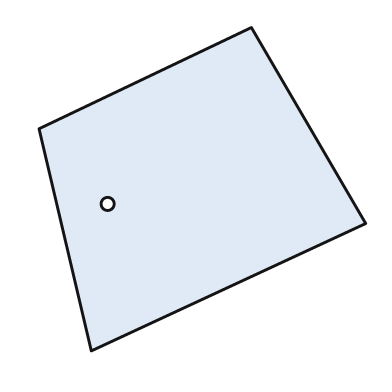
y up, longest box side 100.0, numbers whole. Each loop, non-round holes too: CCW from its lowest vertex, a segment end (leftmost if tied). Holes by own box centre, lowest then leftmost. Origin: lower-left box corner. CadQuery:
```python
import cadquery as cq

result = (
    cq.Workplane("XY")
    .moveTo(16.0, 0.0)
    .lineTo(100.0, 39.0)
    .lineTo(65.0, 99.0)
    .lineTo(0.0, 68.0)
    .close()
    .moveTo(21.0, 45.0)
    .circle(2.0)
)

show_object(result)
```